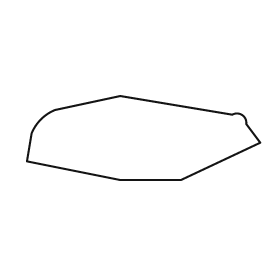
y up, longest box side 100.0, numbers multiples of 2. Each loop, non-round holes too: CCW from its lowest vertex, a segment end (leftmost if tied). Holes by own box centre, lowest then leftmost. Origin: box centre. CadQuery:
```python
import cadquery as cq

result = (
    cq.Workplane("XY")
    .moveTo(-10.0, -18.0)
    .lineTo(16.0, -18.0)
    .lineTo(50.0, -2.0)
    .lineTo(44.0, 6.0)
    .threePointArc((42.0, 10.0), (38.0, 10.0))
    .lineTo(-10.0, 18.0)
    .lineTo(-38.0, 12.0)
    .threePointArc((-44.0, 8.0), (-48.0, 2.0))
    .lineTo(-50.0, -10.0)
    .close()
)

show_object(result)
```